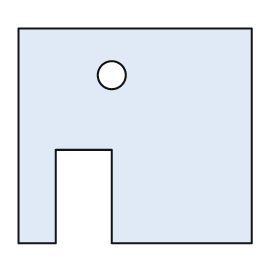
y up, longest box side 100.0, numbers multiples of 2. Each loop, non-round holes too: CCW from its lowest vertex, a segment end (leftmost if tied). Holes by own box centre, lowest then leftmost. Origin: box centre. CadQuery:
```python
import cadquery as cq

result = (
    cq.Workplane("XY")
    .moveTo(-50.0, -46.0)
    .lineTo(-34.0, -46.0)
    .lineTo(-34.0, -6.0)
    .lineTo(-10.0, -6.0)
    .lineTo(-10.0, -46.0)
    .lineTo(50.0, -46.0)
    .lineTo(50.0, 46.0)
    .lineTo(-50.0, 46.0)
    .close()
    .moveTo(-10.0, 26.0)
    .circle(6.0)
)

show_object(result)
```